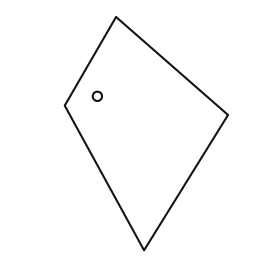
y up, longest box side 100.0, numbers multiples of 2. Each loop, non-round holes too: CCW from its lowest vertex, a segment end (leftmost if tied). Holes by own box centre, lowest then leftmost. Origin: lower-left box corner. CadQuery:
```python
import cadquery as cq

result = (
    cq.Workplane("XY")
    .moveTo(34.0, 0.0)
    .lineTo(70.0, 58.0)
    .lineTo(22.0, 100.0)
    .lineTo(0.0, 62.0)
    .close()
    .moveTo(14.0, 66.0)
    .circle(2.0)
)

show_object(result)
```